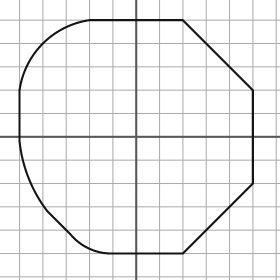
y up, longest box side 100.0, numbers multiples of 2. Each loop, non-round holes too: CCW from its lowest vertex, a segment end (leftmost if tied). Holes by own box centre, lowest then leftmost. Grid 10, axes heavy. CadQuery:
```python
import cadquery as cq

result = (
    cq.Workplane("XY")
    .moveTo(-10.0, -50.0)
    .lineTo(20.0, -50.0)
    .lineTo(50.0, -20.0)
    .lineTo(50.0, 20.0)
    .lineTo(20.0, 50.0)
    .lineTo(-20.0, 50.0)
    .threePointArc((-40.0, 40.0), (-50.0, 20.0))
    .lineTo(-50.0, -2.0)
    .threePointArc((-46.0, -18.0), (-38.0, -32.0))
    .lineTo(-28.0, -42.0)
    .threePointArc((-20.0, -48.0), (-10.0, -50.0))
    .close()
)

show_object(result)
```